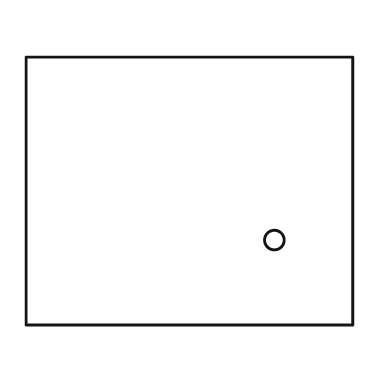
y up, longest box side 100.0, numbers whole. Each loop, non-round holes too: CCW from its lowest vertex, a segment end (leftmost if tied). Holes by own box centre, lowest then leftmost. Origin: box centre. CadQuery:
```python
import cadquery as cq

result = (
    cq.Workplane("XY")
    .moveTo(-50.0, -41.0)
    .lineTo(50.0, -41.0)
    .lineTo(50.0, 41.0)
    .lineTo(-50.0, 41.0)
    .close()
    .moveTo(26.0, -15.0)
    .circle(3.0)
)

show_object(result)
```